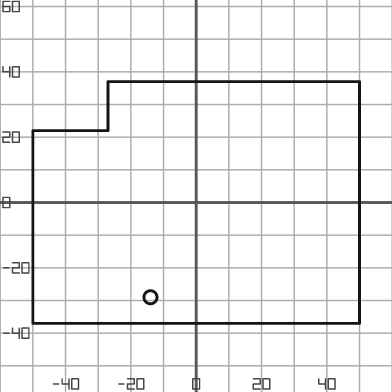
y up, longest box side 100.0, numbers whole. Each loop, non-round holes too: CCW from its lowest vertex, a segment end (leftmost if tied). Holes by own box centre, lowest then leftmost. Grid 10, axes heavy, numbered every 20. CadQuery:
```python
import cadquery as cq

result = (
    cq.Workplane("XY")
    .moveTo(-50.0, -37.0)
    .lineTo(50.0, -37.0)
    .lineTo(50.0, 37.0)
    .lineTo(-27.0, 37.0)
    .lineTo(-27.0, 22.0)
    .lineTo(-50.0, 22.0)
    .close()
    .moveTo(-14.0, -29.0)
    .circle(2.0)
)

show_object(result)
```